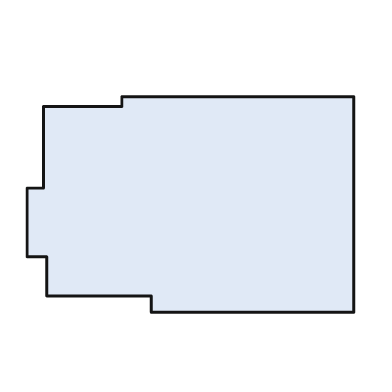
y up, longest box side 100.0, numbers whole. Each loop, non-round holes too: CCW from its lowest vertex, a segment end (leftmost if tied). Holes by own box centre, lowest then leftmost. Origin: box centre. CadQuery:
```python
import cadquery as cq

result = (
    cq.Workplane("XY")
    .moveTo(-12.0, -33.0)
    .lineTo(50.0, -33.0)
    .lineTo(50.0, 33.0)
    .lineTo(-21.0, 33.0)
    .lineTo(-21.0, 30.0)
    .lineTo(-45.0, 30.0)
    .lineTo(-45.0, 5.0)
    .lineTo(-50.0, 5.0)
    .lineTo(-50.0, -16.0)
    .lineTo(-44.0, -16.0)
    .lineTo(-44.0, -28.0)
    .lineTo(-12.0, -28.0)
    .close()
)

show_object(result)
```